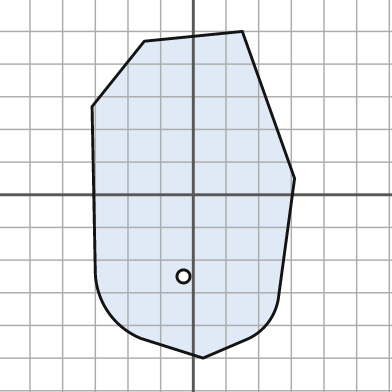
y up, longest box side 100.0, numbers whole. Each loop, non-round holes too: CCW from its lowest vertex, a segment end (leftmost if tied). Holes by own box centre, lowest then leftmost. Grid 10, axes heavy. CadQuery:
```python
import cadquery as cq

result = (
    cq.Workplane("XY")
    .moveTo(3.0, -50.0)
    .lineTo(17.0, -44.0)
    .threePointArc((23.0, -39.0), (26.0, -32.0))
    .lineTo(31.0, 5.0)
    .lineTo(15.0, 50.0)
    .lineTo(-15.0, 47.0)
    .lineTo(-31.0, 27.0)
    .lineTo(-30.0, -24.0)
    .threePointArc((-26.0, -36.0), (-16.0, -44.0))
    .close()
    .moveTo(-3.0, -25.0)
    .circle(2.0)
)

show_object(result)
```